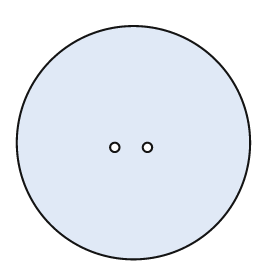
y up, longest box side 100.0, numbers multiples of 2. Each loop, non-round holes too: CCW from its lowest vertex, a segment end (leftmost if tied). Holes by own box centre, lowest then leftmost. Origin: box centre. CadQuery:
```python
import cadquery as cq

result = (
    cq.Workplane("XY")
    .moveTo(0.0, 0.0)
    .circle(50.0)
    .moveTo(-8.0, -2.0)
    .circle(2.0)
    .moveTo(6.0, -2.0)
    .circle(2.0)
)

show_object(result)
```